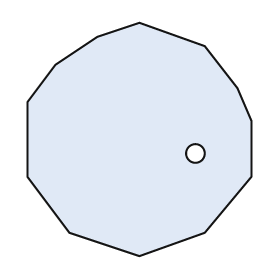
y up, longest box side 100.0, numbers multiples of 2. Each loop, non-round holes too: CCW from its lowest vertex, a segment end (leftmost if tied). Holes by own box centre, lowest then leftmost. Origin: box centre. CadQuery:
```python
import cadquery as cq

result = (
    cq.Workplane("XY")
    .moveTo(0.0, -50.0)
    .lineTo(28.0, -40.0)
    .lineTo(48.0, -16.0)
    .lineTo(48.0, 8.0)
    .lineTo(42.0, 22.0)
    .lineTo(28.0, 40.0)
    .lineTo(0.0, 50.0)
    .lineTo(-18.0, 44.0)
    .lineTo(-36.0, 32.0)
    .lineTo(-48.0, 16.0)
    .lineTo(-48.0, -16.0)
    .lineTo(-30.0, -40.0)
    .close()
    .moveTo(24.0, -6.0)
    .circle(4.0)
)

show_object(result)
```